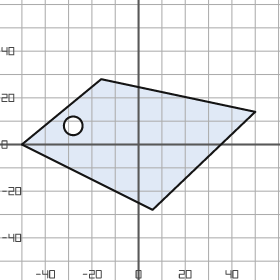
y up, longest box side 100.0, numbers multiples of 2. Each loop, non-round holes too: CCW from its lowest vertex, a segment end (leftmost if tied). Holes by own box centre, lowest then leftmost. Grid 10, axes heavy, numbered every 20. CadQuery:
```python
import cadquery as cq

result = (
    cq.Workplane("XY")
    .moveTo(6.0, -28.0)
    .lineTo(50.0, 14.0)
    .lineTo(-16.0, 28.0)
    .lineTo(-50.0, 0.0)
    .close()
    .moveTo(-28.0, 8.0)
    .circle(4.0)
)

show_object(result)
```